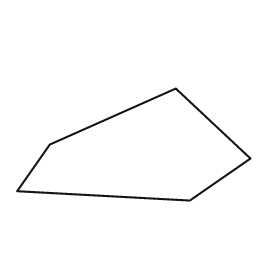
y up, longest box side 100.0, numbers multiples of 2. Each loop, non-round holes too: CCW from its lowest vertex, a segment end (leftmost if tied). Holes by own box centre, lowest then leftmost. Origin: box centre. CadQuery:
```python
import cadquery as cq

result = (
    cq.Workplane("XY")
    .moveTo(24.0, -24.0)
    .lineTo(50.0, -6.0)
    .lineTo(18.0, 24.0)
    .lineTo(-36.0, 0.0)
    .lineTo(-50.0, -20.0)
    .close()
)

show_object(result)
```